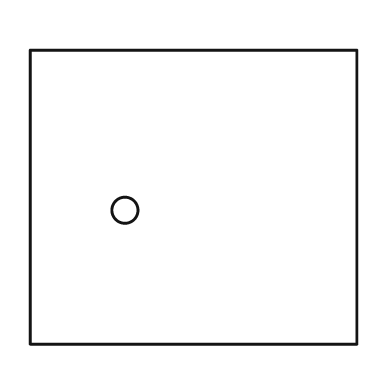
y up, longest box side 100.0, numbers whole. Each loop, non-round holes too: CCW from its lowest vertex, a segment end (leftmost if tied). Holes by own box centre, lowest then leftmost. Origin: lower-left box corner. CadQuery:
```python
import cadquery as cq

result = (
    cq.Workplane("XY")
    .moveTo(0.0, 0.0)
    .lineTo(100.0, 0.0)
    .lineTo(100.0, 90.0)
    .lineTo(0.0, 90.0)
    .close()
    .moveTo(29.0, 41.0)
    .circle(4.0)
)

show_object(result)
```